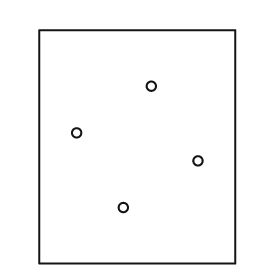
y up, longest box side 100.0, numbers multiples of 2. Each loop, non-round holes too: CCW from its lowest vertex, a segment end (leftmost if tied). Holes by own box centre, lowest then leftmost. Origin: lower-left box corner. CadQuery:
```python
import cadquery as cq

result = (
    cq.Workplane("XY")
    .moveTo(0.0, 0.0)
    .lineTo(84.0, 0.0)
    .lineTo(84.0, 100.0)
    .lineTo(0.0, 100.0)
    .close()
    .moveTo(36.0, 24.0)
    .circle(2.0)
    .moveTo(68.0, 44.0)
    .circle(2.0)
    .moveTo(16.0, 56.0)
    .circle(2.0)
    .moveTo(48.0, 76.0)
    .circle(2.0)
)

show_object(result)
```